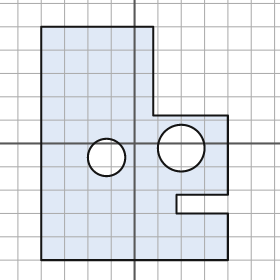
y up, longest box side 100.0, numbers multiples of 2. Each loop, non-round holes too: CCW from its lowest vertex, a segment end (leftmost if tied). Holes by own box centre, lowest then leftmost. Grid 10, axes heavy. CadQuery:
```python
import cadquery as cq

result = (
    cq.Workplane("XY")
    .moveTo(-40.0, -50.0)
    .lineTo(40.0, -50.0)
    .lineTo(40.0, -30.0)
    .lineTo(18.0, -30.0)
    .lineTo(18.0, -22.0)
    .lineTo(40.0, -22.0)
    .lineTo(40.0, 12.0)
    .lineTo(8.0, 12.0)
    .lineTo(8.0, 50.0)
    .lineTo(-40.0, 50.0)
    .close()
    .moveTo(-12.0, -6.0)
    .circle(8.0)
    .moveTo(20.0, -2.0)
    .circle(10.0)
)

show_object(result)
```